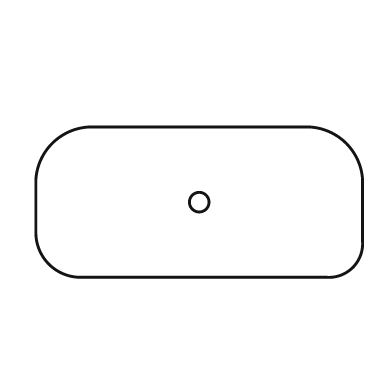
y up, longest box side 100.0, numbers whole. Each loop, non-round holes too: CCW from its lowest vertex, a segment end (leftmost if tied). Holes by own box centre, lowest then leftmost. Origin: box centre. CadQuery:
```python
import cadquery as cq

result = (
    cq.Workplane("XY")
    .moveTo(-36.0, -23.0)
    .lineTo(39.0, -23.0)
    .threePointArc((47.0, -20.0), (50.0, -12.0))
    .lineTo(50.0, 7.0)
    .threePointArc((45.0, 18.0), (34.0, 23.0))
    .lineTo(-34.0, 23.0)
    .threePointArc((-45.0, 18.0), (-50.0, 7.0))
    .lineTo(-50.0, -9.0)
    .threePointArc((-46.0, -19.0), (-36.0, -23.0))
    .close()
    .moveTo(0.0, 0.0)
    .circle(3.0)
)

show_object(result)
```